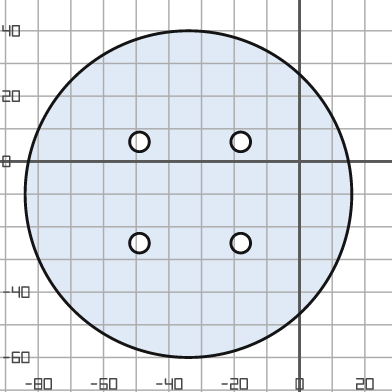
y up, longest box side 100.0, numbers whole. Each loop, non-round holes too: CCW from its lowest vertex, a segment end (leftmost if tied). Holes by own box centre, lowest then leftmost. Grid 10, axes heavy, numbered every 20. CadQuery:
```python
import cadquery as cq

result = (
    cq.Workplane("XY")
    .moveTo(-34.0, -10.0)
    .circle(50.0)
    .moveTo(-49.0, -25.0)
    .circle(3.0)
    .moveTo(-18.0, -25.0)
    .circle(3.0)
    .moveTo(-49.0, 6.0)
    .circle(3.0)
    .moveTo(-18.0, 6.0)
    .circle(3.0)
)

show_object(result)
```